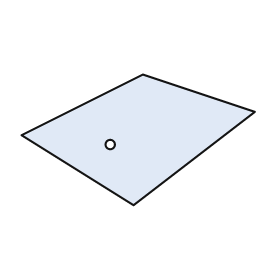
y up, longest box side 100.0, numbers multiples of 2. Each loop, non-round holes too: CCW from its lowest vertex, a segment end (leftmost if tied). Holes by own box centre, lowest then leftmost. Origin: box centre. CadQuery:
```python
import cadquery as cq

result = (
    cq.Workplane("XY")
    .moveTo(-2.0, -28.0)
    .lineTo(50.0, 12.0)
    .lineTo(2.0, 28.0)
    .lineTo(-50.0, 2.0)
    .close()
    .moveTo(-12.0, -2.0)
    .circle(2.0)
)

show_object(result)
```